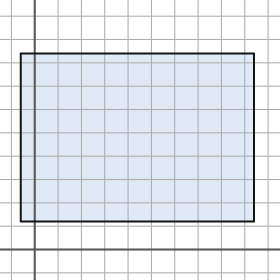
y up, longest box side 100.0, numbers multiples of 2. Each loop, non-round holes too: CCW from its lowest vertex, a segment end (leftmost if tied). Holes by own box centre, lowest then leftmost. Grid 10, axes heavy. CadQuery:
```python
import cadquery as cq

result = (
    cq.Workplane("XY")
    .moveTo(-6.0, 12.0)
    .lineTo(94.0, 12.0)
    .lineTo(94.0, 84.0)
    .lineTo(-6.0, 84.0)
    .close()
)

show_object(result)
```